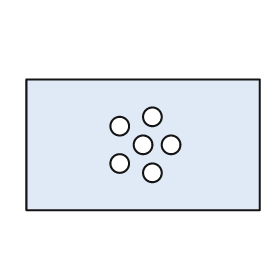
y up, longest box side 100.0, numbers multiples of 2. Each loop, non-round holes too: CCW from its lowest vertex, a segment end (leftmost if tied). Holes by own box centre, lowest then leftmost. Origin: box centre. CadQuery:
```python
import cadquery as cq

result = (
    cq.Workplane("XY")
    .moveTo(-50.0, -28.0)
    .lineTo(50.0, -28.0)
    .lineTo(50.0, 28.0)
    .lineTo(-50.0, 28.0)
    .close()
    .moveTo(4.0, -12.0)
    .circle(4.0)
    .moveTo(-10.0, -8.0)
    .circle(4.0)
    .moveTo(0.0, 0.0)
    .circle(4.0)
    .moveTo(12.0, 0.0)
    .circle(4.0)
    .moveTo(-10.0, 8.0)
    .circle(4.0)
    .moveTo(4.0, 12.0)
    .circle(4.0)
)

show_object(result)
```